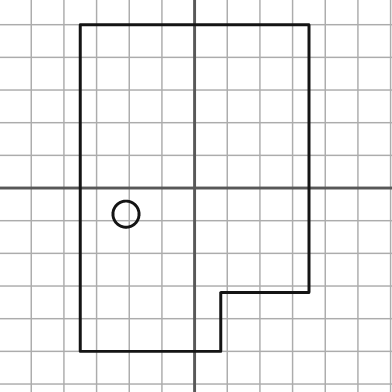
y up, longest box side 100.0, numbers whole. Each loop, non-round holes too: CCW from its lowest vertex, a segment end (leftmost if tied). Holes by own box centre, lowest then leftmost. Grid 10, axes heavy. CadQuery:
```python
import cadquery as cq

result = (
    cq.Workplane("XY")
    .moveTo(-35.0, -50.0)
    .lineTo(8.0, -50.0)
    .lineTo(8.0, -32.0)
    .lineTo(35.0, -32.0)
    .lineTo(35.0, 50.0)
    .lineTo(-35.0, 50.0)
    .close()
    .moveTo(-21.0, -8.0)
    .circle(4.0)
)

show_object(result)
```